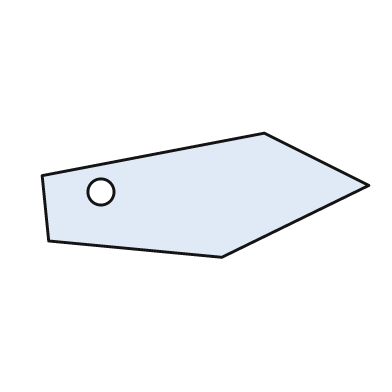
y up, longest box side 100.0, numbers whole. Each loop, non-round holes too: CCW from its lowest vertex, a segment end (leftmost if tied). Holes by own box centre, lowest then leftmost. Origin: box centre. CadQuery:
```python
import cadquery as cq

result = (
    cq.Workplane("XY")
    .moveTo(5.0, -19.0)
    .lineTo(50.0, 3.0)
    .lineTo(18.0, 19.0)
    .lineTo(-50.0, 6.0)
    .lineTo(-48.0, -14.0)
    .close()
    .moveTo(-32.0, 1.0)
    .circle(4.0)
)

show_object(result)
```